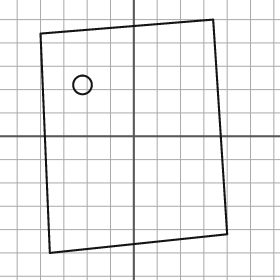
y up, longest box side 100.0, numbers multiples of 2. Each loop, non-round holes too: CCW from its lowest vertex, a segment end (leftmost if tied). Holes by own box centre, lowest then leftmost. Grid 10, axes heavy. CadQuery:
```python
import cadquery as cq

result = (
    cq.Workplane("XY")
    .moveTo(-36.0, -50.0)
    .lineTo(40.0, -42.0)
    .lineTo(34.0, 50.0)
    .lineTo(-40.0, 44.0)
    .close()
    .moveTo(-22.0, 22.0)
    .circle(4.0)
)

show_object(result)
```